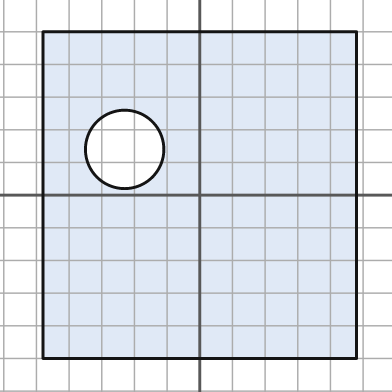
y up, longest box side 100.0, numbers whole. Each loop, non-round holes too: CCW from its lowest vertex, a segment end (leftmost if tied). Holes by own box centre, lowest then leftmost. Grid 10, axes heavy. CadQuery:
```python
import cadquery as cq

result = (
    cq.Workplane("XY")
    .moveTo(-48.0, -50.0)
    .lineTo(48.0, -50.0)
    .lineTo(48.0, 50.0)
    .lineTo(-48.0, 50.0)
    .close()
    .moveTo(-23.0, 14.0)
    .circle(12.0)
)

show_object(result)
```